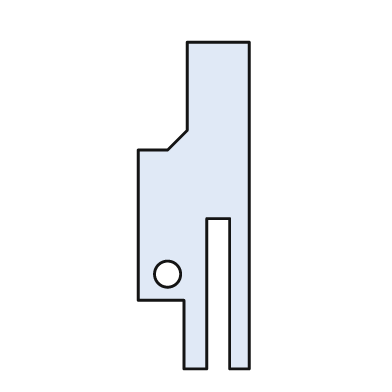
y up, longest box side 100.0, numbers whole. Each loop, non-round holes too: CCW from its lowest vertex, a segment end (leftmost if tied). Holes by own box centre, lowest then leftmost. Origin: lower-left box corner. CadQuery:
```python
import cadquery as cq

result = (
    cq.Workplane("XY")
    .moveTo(14.0, 0.0)
    .lineTo(21.0, 0.0)
    .lineTo(21.0, 46.0)
    .lineTo(28.0, 46.0)
    .lineTo(28.0, 0.0)
    .lineTo(34.0, 0.0)
    .lineTo(34.0, 100.0)
    .lineTo(15.0, 100.0)
    .lineTo(15.0, 73.0)
    .lineTo(9.0, 67.0)
    .lineTo(0.0, 67.0)
    .lineTo(0.0, 21.0)
    .lineTo(14.0, 21.0)
    .close()
    .moveTo(9.0, 29.0)
    .circle(4.0)
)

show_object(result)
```